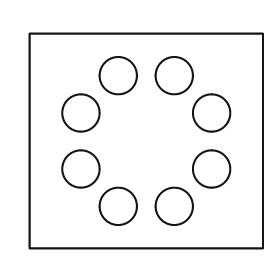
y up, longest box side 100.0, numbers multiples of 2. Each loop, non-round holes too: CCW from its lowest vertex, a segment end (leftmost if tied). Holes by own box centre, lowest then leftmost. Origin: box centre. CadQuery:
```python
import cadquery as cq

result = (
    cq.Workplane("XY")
    .moveTo(-50.0, -46.0)
    .lineTo(50.0, -46.0)
    .lineTo(50.0, 46.0)
    .lineTo(-50.0, 46.0)
    .close()
    .moveTo(-12.0, -28.0)
    .circle(8.0)
    .moveTo(12.0, -28.0)
    .circle(8.0)
    .moveTo(-28.0, -12.0)
    .circle(8.0)
    .moveTo(28.0, -12.0)
    .circle(8.0)
    .moveTo(-28.0, 12.0)
    .circle(8.0)
    .moveTo(28.0, 12.0)
    .circle(8.0)
    .moveTo(-12.0, 28.0)
    .circle(8.0)
    .moveTo(12.0, 28.0)
    .circle(8.0)
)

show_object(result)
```